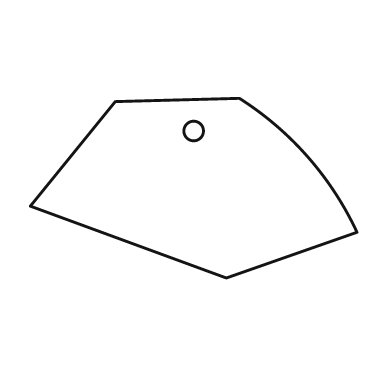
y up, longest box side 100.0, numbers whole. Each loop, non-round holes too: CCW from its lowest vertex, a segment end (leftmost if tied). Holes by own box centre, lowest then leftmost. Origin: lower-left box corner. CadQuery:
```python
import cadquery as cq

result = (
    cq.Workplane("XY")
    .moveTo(60.0, 0.0)
    .lineTo(100.0, 14.0)
    .threePointArc((85.0, 37.0), (64.0, 55.0))
    .lineTo(26.0, 54.0)
    .lineTo(0.0, 22.0)
    .close()
    .moveTo(50.0, 45.0)
    .circle(3.0)
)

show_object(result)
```